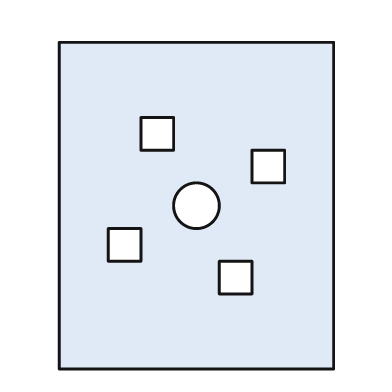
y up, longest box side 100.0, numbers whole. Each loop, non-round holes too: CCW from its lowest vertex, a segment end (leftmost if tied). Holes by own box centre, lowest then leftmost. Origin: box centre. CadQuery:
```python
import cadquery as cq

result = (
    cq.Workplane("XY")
    .moveTo(-42.0, -50.0)
    .lineTo(42.0, -50.0)
    .lineTo(42.0, 50.0)
    .lineTo(-42.0, 50.0)
    .close()
    .moveTo(7.0, -27.0)
    .lineTo(17.0, -27.0)
    .lineTo(17.0, -17.0)
    .lineTo(7.0, -17.0)
    .close()
    .moveTo(-27.0, -17.0)
    .lineTo(-17.0, -17.0)
    .lineTo(-17.0, -7.0)
    .lineTo(-27.0, -7.0)
    .close()
    .moveTo(0.0, 0.0)
    .circle(7.0)
    .moveTo(17.0, 7.0)
    .lineTo(27.0, 7.0)
    .lineTo(27.0, 17.0)
    .lineTo(17.0, 17.0)
    .close()
    .moveTo(-17.0, 17.0)
    .lineTo(-7.0, 17.0)
    .lineTo(-7.0, 27.0)
    .lineTo(-17.0, 27.0)
    .close()
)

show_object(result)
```